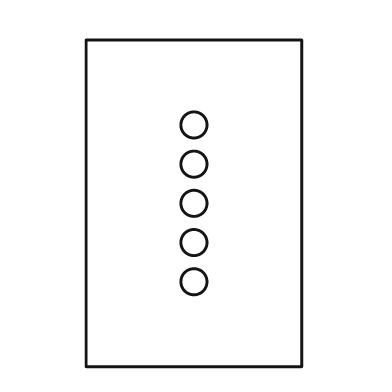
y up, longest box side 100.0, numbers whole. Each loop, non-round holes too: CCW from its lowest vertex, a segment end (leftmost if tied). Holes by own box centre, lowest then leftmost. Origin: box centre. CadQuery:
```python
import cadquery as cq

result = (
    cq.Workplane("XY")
    .moveTo(-33.0, -50.0)
    .lineTo(33.0, -50.0)
    .lineTo(33.0, 50.0)
    .lineTo(-33.0, 50.0)
    .close()
    .moveTo(0.0, -24.0)
    .circle(4.0)
    .moveTo(0.0, -12.0)
    .circle(4.0)
    .moveTo(0.0, 0.0)
    .circle(4.0)
    .moveTo(0.0, 12.0)
    .circle(4.0)
    .moveTo(0.0, 24.0)
    .circle(4.0)
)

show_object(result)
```